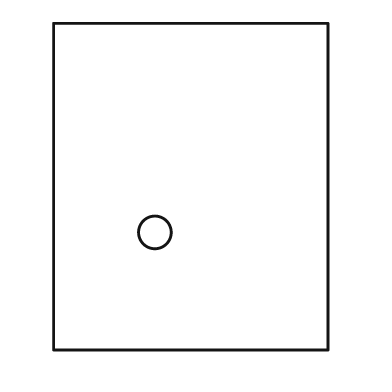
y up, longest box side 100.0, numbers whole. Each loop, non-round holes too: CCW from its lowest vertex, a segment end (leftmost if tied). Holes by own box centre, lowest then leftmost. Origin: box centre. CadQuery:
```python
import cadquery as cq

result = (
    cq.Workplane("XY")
    .moveTo(-42.0, -50.0)
    .lineTo(42.0, -50.0)
    .lineTo(42.0, 50.0)
    .lineTo(-42.0, 50.0)
    .close()
    .moveTo(-11.0, -14.0)
    .circle(5.0)
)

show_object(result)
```